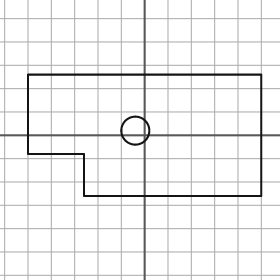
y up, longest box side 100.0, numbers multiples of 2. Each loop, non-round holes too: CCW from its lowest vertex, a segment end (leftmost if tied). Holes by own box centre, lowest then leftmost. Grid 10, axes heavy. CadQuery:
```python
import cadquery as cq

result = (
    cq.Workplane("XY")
    .moveTo(-26.0, -26.0)
    .lineTo(50.0, -26.0)
    .lineTo(50.0, 26.0)
    .lineTo(-50.0, 26.0)
    .lineTo(-50.0, -8.0)
    .lineTo(-26.0, -8.0)
    .close()
    .moveTo(-4.0, 2.0)
    .circle(6.0)
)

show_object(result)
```